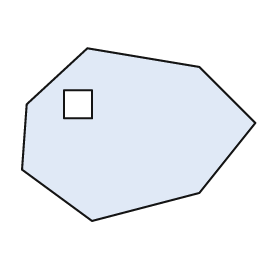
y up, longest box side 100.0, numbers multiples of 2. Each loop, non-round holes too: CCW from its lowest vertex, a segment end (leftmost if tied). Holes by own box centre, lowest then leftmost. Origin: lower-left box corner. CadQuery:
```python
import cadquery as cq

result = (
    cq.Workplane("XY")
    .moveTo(30.0, 0.0)
    .lineTo(76.0, 12.0)
    .lineTo(100.0, 42.0)
    .lineTo(76.0, 66.0)
    .lineTo(28.0, 74.0)
    .lineTo(2.0, 50.0)
    .lineTo(0.0, 22.0)
    .close()
    .moveTo(18.0, 44.0)
    .lineTo(30.0, 44.0)
    .lineTo(30.0, 56.0)
    .lineTo(18.0, 56.0)
    .close()
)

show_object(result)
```